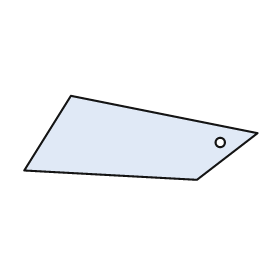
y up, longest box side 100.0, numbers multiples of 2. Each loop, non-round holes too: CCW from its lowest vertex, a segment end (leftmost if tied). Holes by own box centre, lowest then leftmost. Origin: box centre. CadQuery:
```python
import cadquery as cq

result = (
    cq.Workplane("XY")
    .moveTo(24.0, -18.0)
    .lineTo(50.0, 2.0)
    .lineTo(-30.0, 18.0)
    .lineTo(-50.0, -14.0)
    .close()
    .moveTo(34.0, -2.0)
    .circle(2.0)
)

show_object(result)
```